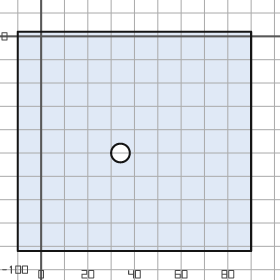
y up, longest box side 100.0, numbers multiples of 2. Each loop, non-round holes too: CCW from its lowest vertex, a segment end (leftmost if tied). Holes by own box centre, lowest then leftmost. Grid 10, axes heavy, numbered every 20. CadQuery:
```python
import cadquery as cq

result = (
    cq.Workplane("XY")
    .moveTo(-10.0, -92.0)
    .lineTo(90.0, -92.0)
    .lineTo(90.0, 2.0)
    .lineTo(-10.0, 2.0)
    .close()
    .moveTo(34.0, -50.0)
    .circle(4.0)
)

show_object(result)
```